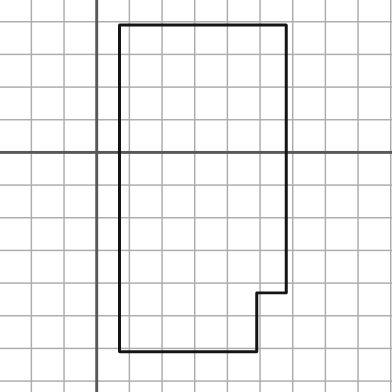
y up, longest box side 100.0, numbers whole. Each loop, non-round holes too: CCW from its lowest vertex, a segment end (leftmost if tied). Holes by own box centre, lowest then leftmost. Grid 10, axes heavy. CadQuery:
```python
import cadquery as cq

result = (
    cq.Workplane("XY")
    .moveTo(7.0, -61.0)
    .lineTo(49.0, -61.0)
    .lineTo(49.0, -43.0)
    .lineTo(58.0, -43.0)
    .lineTo(58.0, 39.0)
    .lineTo(7.0, 39.0)
    .close()
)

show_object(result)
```